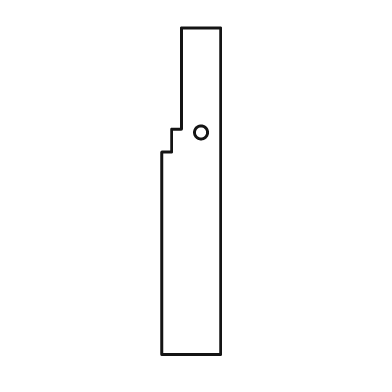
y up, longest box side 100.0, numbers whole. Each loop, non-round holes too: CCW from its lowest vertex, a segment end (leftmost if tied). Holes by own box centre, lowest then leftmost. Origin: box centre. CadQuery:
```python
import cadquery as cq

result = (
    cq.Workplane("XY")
    .moveTo(-9.0, -50.0)
    .lineTo(9.0, -50.0)
    .lineTo(9.0, 50.0)
    .lineTo(-3.0, 50.0)
    .lineTo(-3.0, 19.0)
    .lineTo(-6.0, 19.0)
    .lineTo(-6.0, 12.0)
    .lineTo(-9.0, 12.0)
    .close()
    .moveTo(3.0, 18.0)
    .circle(2.0)
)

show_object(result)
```